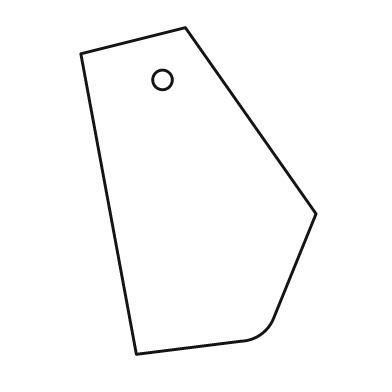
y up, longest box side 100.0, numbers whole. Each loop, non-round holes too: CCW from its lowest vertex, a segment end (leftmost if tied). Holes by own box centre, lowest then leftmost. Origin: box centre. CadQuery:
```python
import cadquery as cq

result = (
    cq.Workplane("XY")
    .moveTo(-19.0, -50.0)
    .lineTo(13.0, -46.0)
    .threePointArc((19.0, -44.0), (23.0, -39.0))
    .lineTo(36.0, -7.0)
    .lineTo(-4.0, 50.0)
    .lineTo(-36.0, 42.0)
    .close()
    .moveTo(-11.0, 34.0)
    .circle(3.0)
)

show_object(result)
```